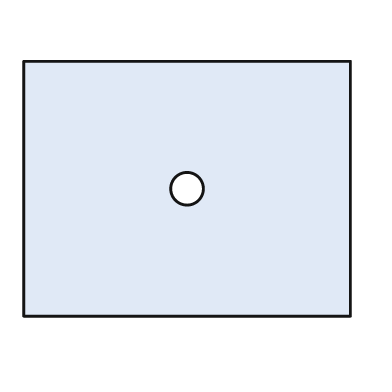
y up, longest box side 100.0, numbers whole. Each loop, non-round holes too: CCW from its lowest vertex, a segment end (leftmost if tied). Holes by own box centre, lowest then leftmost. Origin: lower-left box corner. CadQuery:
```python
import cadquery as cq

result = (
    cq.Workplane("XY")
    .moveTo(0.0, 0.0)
    .lineTo(100.0, 0.0)
    .lineTo(100.0, 78.0)
    .lineTo(0.0, 78.0)
    .close()
    .moveTo(50.0, 39.0)
    .circle(5.0)
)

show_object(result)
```